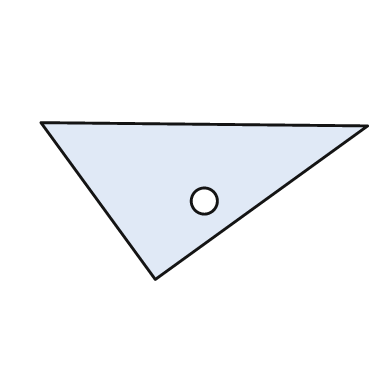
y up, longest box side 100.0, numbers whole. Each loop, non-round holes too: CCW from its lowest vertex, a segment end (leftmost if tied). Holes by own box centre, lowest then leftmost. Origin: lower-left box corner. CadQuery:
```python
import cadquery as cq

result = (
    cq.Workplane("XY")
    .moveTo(35.0, 0.0)
    .lineTo(100.0, 47.0)
    .lineTo(0.0, 48.0)
    .close()
    .moveTo(50.0, 24.0)
    .circle(4.0)
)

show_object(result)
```